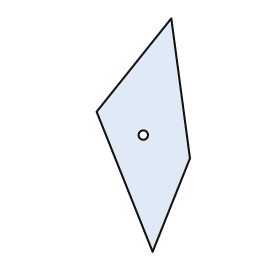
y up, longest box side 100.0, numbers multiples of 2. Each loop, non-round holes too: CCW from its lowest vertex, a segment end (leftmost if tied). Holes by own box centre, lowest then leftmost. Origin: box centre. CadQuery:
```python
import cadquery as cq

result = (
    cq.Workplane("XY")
    .moveTo(4.0, -50.0)
    .lineTo(20.0, -10.0)
    .lineTo(12.0, 50.0)
    .lineTo(-20.0, 10.0)
    .close()
    .moveTo(0.0, 0.0)
    .circle(2.0)
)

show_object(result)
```